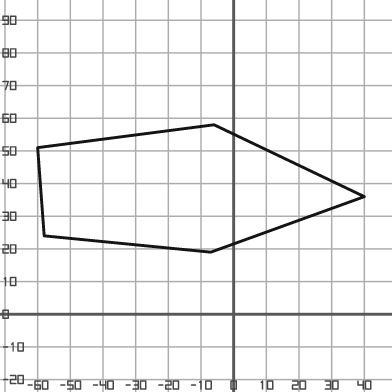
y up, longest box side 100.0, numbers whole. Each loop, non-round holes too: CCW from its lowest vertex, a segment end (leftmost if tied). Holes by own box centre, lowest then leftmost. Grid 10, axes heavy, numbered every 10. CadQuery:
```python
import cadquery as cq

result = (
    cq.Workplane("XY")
    .moveTo(-7.0, 19.0)
    .lineTo(40.0, 36.0)
    .lineTo(-6.0, 58.0)
    .lineTo(-60.0, 51.0)
    .lineTo(-58.0, 24.0)
    .close()
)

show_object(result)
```